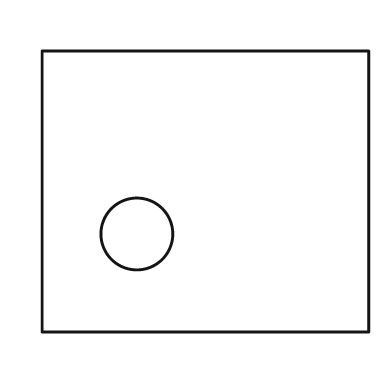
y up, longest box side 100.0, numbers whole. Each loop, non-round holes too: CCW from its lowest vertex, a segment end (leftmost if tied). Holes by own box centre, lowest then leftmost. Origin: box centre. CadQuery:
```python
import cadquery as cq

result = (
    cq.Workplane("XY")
    .moveTo(-50.0, -43.0)
    .lineTo(50.0, -43.0)
    .lineTo(50.0, 43.0)
    .lineTo(-50.0, 43.0)
    .close()
    .moveTo(-21.0, -13.0)
    .circle(11.0)
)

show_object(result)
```